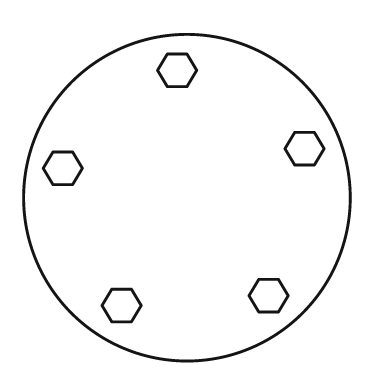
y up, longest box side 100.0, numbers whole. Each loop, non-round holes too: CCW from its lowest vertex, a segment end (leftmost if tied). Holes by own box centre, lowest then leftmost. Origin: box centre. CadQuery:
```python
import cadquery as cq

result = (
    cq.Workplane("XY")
    .moveTo(0.0, 0.0)
    .circle(50.0)
    .moveTo(-23.0, -38.0)
    .lineTo(-17.0, -38.0)
    .lineTo(-14.0, -33.0)
    .lineTo(-17.0, -28.0)
    .lineTo(-23.0, -28.0)
    .lineTo(-26.0, -33.0)
    .close()
    .moveTo(22.0, -35.0)
    .lineTo(28.0, -35.0)
    .lineTo(31.0, -30.0)
    .lineTo(28.0, -25.0)
    .lineTo(22.0, -25.0)
    .lineTo(19.0, -30.0)
    .close()
    .moveTo(-41.0, 4.0)
    .lineTo(-35.0, 4.0)
    .lineTo(-32.0, 9.0)
    .lineTo(-35.0, 14.0)
    .lineTo(-41.0, 14.0)
    .lineTo(-44.0, 9.0)
    .close()
    .moveTo(33.0, 10.0)
    .lineTo(39.0, 10.0)
    .lineTo(42.0, 15.0)
    .lineTo(39.0, 20.0)
    .lineTo(33.0, 20.0)
    .lineTo(30.0, 15.0)
    .close()
    .moveTo(-6.0, 34.0)
    .lineTo(0.0, 34.0)
    .lineTo(3.0, 39.0)
    .lineTo(0.0, 44.0)
    .lineTo(-6.0, 44.0)
    .lineTo(-9.0, 39.0)
    .close()
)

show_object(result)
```